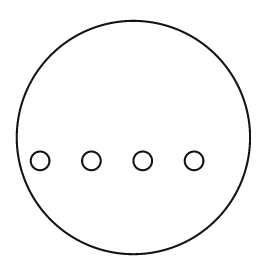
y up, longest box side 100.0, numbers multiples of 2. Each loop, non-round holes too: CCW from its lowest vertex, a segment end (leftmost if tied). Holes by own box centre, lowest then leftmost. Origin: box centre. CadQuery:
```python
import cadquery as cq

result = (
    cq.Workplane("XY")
    .moveTo(0.0, 0.0)
    .circle(50.0)
    .moveTo(-40.0, -10.0)
    .circle(4.0)
    .moveTo(-18.0, -10.0)
    .circle(4.0)
    .moveTo(4.0, -10.0)
    .circle(4.0)
    .moveTo(26.0, -10.0)
    .circle(4.0)
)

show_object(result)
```